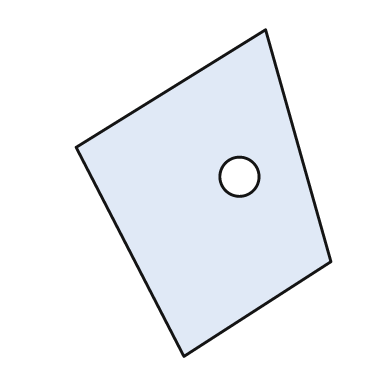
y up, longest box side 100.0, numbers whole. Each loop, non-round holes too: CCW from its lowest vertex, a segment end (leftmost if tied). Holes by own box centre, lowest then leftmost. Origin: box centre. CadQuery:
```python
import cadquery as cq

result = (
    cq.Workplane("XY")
    .moveTo(-6.0, -50.0)
    .lineTo(39.0, -21.0)
    .lineTo(19.0, 50.0)
    .lineTo(-39.0, 14.0)
    .close()
    .moveTo(11.0, 5.0)
    .circle(6.0)
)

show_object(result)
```